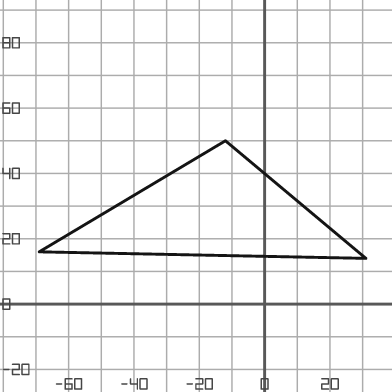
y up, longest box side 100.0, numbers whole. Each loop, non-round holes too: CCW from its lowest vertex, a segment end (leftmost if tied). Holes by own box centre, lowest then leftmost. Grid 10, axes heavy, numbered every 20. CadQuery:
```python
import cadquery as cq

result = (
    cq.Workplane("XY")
    .moveTo(31.0, 14.0)
    .lineTo(-12.0, 50.0)
    .lineTo(-69.0, 16.0)
    .close()
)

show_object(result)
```